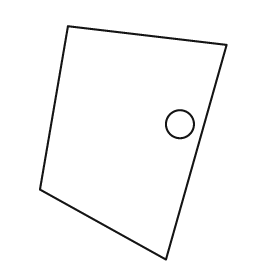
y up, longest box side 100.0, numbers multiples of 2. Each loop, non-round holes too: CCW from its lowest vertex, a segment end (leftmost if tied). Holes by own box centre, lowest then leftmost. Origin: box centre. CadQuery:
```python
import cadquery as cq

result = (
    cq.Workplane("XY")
    .moveTo(14.0, -50.0)
    .lineTo(40.0, 42.0)
    .lineTo(-28.0, 50.0)
    .lineTo(-40.0, -20.0)
    .close()
    .moveTo(20.0, 8.0)
    .circle(6.0)
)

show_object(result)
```